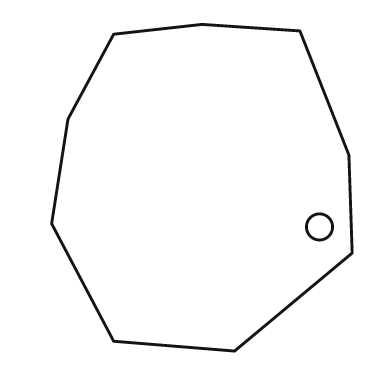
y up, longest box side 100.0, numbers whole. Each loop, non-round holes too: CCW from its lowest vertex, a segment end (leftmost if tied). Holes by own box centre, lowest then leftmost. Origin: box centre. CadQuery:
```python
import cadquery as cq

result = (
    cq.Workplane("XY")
    .moveTo(10.0, -50.0)
    .lineTo(46.0, -20.0)
    .lineTo(45.0, 10.0)
    .lineTo(30.0, 48.0)
    .lineTo(0.0, 50.0)
    .lineTo(-27.0, 47.0)
    .lineTo(-41.0, 21.0)
    .lineTo(-46.0, -11.0)
    .lineTo(-27.0, -47.0)
    .close()
    .moveTo(36.0, -12.0)
    .circle(4.0)
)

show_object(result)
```